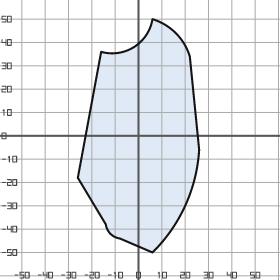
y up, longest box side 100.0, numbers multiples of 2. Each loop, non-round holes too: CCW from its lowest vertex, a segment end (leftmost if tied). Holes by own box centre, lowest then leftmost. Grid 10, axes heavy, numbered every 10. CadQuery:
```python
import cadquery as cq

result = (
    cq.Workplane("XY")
    .moveTo(6.0, -50.0)
    .threePointArc((20.0, -30.0), (26.0, -6.0))
    .lineTo(22.0, 34.0)
    .threePointArc((16.0, 44.0), (6.0, 50.0))
    .threePointArc((-2.0, 38.0), (-16.0, 36.0))
    .lineTo(-26.0, -18.0)
    .lineTo(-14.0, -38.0)
    .threePointArc((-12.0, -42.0), (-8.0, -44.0))
    .close()
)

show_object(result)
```